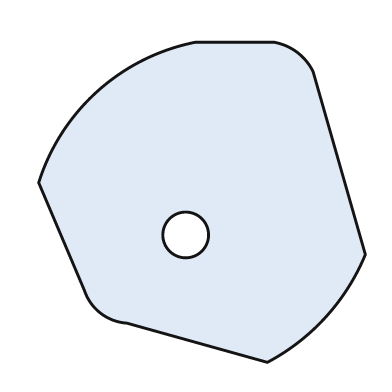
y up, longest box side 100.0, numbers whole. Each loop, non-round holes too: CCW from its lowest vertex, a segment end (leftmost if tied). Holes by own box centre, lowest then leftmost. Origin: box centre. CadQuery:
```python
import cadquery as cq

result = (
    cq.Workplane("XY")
    .moveTo(20.0, -49.0)
    .threePointArc((38.0, -35.0), (50.0, -16.0))
    .lineTo(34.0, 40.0)
    .threePointArc((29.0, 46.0), (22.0, 49.0))
    .lineTo(-2.0, 49.0)
    .threePointArc((-32.0, 34.0), (-50.0, 6.0))
    .lineTo(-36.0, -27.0)
    .threePointArc((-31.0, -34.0), (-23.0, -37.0))
    .close()
    .moveTo(-5.0, -10.0)
    .circle(7.0)
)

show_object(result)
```